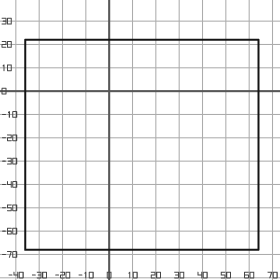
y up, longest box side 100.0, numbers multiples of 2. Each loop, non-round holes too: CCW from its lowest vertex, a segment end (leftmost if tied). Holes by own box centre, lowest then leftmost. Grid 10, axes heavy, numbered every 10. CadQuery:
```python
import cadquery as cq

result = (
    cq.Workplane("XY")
    .moveTo(-36.0, -68.0)
    .lineTo(64.0, -68.0)
    .lineTo(64.0, 22.0)
    .lineTo(-36.0, 22.0)
    .close()
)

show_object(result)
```